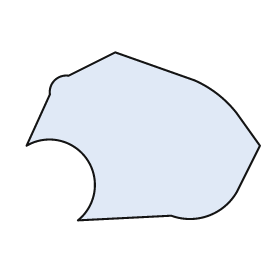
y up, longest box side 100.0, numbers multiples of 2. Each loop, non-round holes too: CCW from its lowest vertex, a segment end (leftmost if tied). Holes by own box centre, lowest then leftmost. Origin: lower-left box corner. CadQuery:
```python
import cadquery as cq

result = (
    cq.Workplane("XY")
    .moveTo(22.0, 0.0)
    .lineTo(62.0, 2.0)
    .threePointArc((78.0, 2.0), (90.0, 12.0))
    .lineTo(100.0, 32.0)
    .lineTo(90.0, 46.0)
    .threePointArc((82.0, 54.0), (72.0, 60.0))
    .lineTo(38.0, 72.0)
    .lineTo(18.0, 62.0)
    .threePointArc((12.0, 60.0), (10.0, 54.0))
    .lineTo(0.0, 32.0)
    .threePointArc((26.0, 26.0), (22.0, 0.0))
    .close()
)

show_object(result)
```